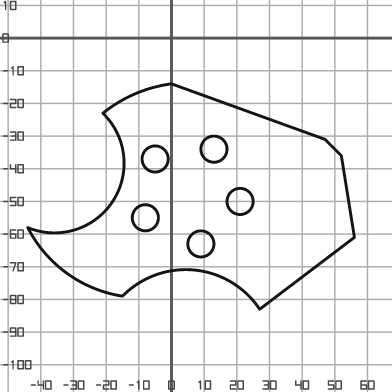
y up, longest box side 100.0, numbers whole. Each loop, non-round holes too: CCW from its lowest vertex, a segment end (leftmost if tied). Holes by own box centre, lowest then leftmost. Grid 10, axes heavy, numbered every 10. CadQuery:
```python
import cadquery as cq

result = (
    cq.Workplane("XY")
    .moveTo(27.0, -83.0)
    .lineTo(56.0, -61.0)
    .lineTo(52.0, -36.0)
    .lineTo(47.0, -31.0)
    .lineTo(0.0, -14.0)
    .threePointArc((-11.0, -17.0), (-21.0, -23.0))
    .threePointArc((-18.0, -50.0), (-44.0, -58.0))
    .threePointArc((-32.0, -72.0), (-15.0, -79.0))
    .threePointArc((7.0, -71.0), (27.0, -83.0))
    .close()
    .moveTo(9.0, -63.0)
    .circle(4.0)
    .moveTo(-8.0, -55.0)
    .circle(4.0)
    .moveTo(21.0, -50.0)
    .circle(4.0)
    .moveTo(-5.0, -37.0)
    .circle(4.0)
    .moveTo(13.0, -34.0)
    .circle(4.0)
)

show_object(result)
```